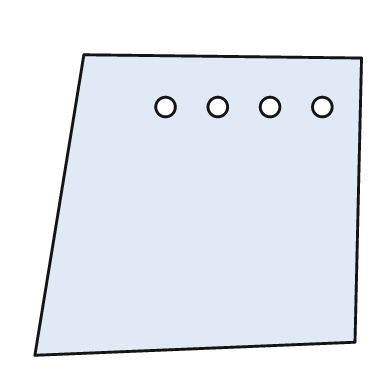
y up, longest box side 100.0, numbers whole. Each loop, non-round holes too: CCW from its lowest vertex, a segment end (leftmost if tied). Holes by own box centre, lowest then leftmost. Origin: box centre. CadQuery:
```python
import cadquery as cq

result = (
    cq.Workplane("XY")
    .moveTo(-50.0, -46.0)
    .lineTo(48.0, -42.0)
    .lineTo(50.0, 45.0)
    .lineTo(-35.0, 46.0)
    .close()
    .moveTo(-10.0, 30.0)
    .circle(3.0)
    .moveTo(6.0, 30.0)
    .circle(3.0)
    .moveTo(22.0, 30.0)
    .circle(3.0)
    .moveTo(38.0, 30.0)
    .circle(3.0)
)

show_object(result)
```